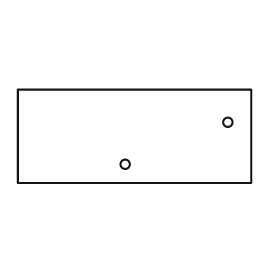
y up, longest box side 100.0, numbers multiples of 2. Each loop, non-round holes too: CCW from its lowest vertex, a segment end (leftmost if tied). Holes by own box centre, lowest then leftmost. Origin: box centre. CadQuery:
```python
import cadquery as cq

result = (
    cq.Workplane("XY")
    .moveTo(-50.0, -20.0)
    .lineTo(50.0, -20.0)
    .lineTo(50.0, 20.0)
    .lineTo(-50.0, 20.0)
    .close()
    .moveTo(-4.0, -12.0)
    .circle(2.0)
    .moveTo(40.0, 6.0)
    .circle(2.0)
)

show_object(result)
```